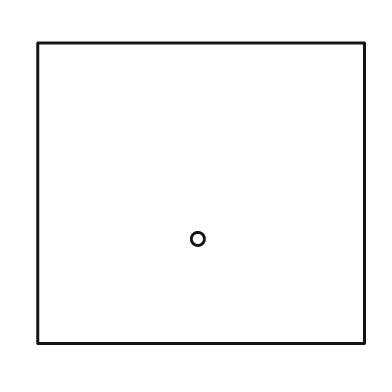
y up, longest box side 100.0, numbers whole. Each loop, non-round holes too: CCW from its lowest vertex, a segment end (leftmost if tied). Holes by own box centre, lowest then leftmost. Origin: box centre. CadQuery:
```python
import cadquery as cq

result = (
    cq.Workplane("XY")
    .moveTo(-50.0, -46.0)
    .lineTo(50.0, -46.0)
    .lineTo(50.0, 46.0)
    .lineTo(-50.0, 46.0)
    .close()
    .moveTo(-1.0, -14.0)
    .circle(2.0)
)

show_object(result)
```